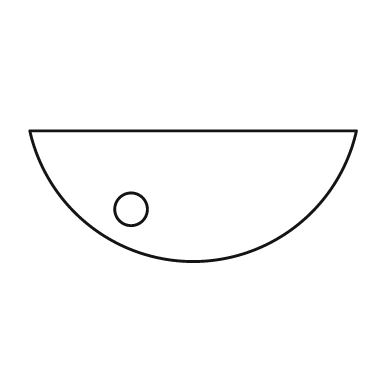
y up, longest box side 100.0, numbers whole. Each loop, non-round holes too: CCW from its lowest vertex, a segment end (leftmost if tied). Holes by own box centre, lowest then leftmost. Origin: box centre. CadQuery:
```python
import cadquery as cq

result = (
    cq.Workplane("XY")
    .moveTo(-50.0, 20.0)
    .threePointArc((0.0, -20.0), (50.0, 20.0))
    .close()
    .moveTo(-19.0, -4.0)
    .circle(5.0)
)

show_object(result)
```